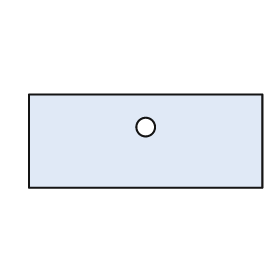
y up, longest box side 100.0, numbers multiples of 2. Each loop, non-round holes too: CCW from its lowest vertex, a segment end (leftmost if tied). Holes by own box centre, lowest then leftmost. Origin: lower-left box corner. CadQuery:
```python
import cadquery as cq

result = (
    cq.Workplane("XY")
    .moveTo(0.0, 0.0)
    .lineTo(100.0, 0.0)
    .lineTo(100.0, 40.0)
    .lineTo(0.0, 40.0)
    .close()
    .moveTo(50.0, 26.0)
    .circle(4.0)
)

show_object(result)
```